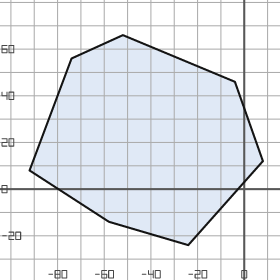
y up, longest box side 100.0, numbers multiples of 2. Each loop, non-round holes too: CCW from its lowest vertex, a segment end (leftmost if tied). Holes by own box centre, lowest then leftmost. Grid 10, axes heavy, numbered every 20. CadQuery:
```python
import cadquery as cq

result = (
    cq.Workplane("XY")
    .moveTo(-24.0, -24.0)
    .lineTo(8.0, 12.0)
    .lineTo(-4.0, 46.0)
    .lineTo(-52.0, 66.0)
    .lineTo(-74.0, 56.0)
    .lineTo(-92.0, 8.0)
    .lineTo(-58.0, -14.0)
    .close()
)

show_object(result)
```